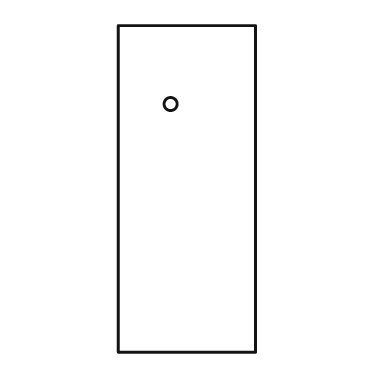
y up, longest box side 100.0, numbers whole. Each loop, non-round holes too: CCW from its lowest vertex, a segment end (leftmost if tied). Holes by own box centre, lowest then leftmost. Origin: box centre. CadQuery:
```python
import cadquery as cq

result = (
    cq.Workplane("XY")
    .moveTo(-21.0, -50.0)
    .lineTo(21.0, -50.0)
    .lineTo(21.0, 50.0)
    .lineTo(-21.0, 50.0)
    .close()
    .moveTo(-5.0, 26.0)
    .circle(2.0)
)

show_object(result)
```